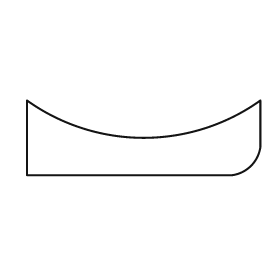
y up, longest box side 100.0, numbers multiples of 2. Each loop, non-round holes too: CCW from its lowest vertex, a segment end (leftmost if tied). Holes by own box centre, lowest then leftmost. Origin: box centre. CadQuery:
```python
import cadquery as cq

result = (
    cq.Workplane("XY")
    .moveTo(-50.0, -16.0)
    .lineTo(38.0, -16.0)
    .threePointArc((46.0, -12.0), (50.0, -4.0))
    .lineTo(50.0, 16.0)
    .threePointArc((0.0, 0.0), (-50.0, 16.0))
    .close()
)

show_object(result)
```